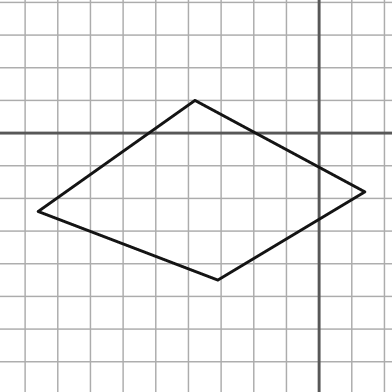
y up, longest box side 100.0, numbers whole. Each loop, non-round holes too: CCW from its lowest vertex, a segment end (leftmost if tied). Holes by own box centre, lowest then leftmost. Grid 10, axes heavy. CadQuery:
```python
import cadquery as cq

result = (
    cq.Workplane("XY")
    .moveTo(-31.0, -45.0)
    .lineTo(14.0, -18.0)
    .lineTo(-38.0, 10.0)
    .lineTo(-86.0, -24.0)
    .close()
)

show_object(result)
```